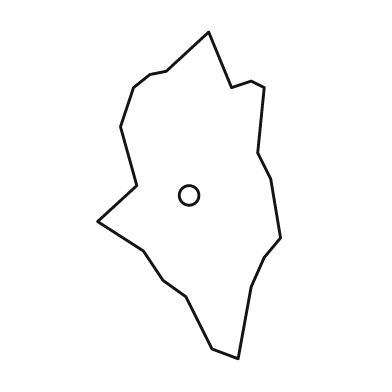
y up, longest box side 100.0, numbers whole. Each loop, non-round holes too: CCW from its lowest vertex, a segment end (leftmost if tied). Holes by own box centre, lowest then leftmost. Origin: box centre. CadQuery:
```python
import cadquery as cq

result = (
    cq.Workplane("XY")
    .moveTo(15.0, -50.0)
    .lineTo(19.0, -28.0)
    .lineTo(23.0, -19.0)
    .lineTo(28.0, -13.0)
    .lineTo(25.0, 5.0)
    .lineTo(21.0, 13.0)
    .lineTo(23.0, 33.0)
    .lineTo(19.0, 35.0)
    .lineTo(13.0, 33.0)
    .lineTo(6.0, 50.0)
    .lineTo(-7.0, 38.0)
    .lineTo(-12.0, 37.0)
    .lineTo(-17.0, 33.0)
    .lineTo(-21.0, 21.0)
    .lineTo(-16.0, 3.0)
    .lineTo(-28.0, -8.0)
    .lineTo(-14.0, -17.0)
    .lineTo(-8.0, -26.0)
    .lineTo(-1.0, -31.0)
    .lineTo(7.0, -47.0)
    .close()
    .moveTo(0.0, 0.0)
    .circle(3.0)
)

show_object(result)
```